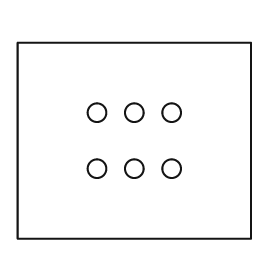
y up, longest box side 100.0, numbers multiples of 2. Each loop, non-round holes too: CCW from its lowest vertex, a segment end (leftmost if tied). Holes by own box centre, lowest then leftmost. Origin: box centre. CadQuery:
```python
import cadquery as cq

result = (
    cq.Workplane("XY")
    .moveTo(-50.0, -42.0)
    .lineTo(50.0, -42.0)
    .lineTo(50.0, 42.0)
    .lineTo(-50.0, 42.0)
    .close()
    .moveTo(-16.0, -12.0)
    .circle(4.0)
    .moveTo(0.0, -12.0)
    .circle(4.0)
    .moveTo(16.0, -12.0)
    .circle(4.0)
    .moveTo(-16.0, 12.0)
    .circle(4.0)
    .moveTo(0.0, 12.0)
    .circle(4.0)
    .moveTo(16.0, 12.0)
    .circle(4.0)
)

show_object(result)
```